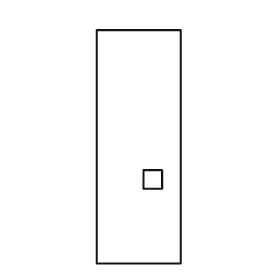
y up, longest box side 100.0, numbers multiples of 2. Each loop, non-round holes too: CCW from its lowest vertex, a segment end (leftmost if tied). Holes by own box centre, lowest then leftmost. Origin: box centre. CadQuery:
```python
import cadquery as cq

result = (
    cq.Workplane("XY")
    .moveTo(-18.0, -50.0)
    .lineTo(18.0, -50.0)
    .lineTo(18.0, 50.0)
    .lineTo(-18.0, 50.0)
    .close()
    .moveTo(2.0, -18.0)
    .lineTo(10.0, -18.0)
    .lineTo(10.0, -10.0)
    .lineTo(2.0, -10.0)
    .close()
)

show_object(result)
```